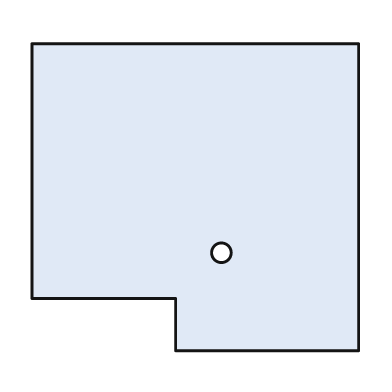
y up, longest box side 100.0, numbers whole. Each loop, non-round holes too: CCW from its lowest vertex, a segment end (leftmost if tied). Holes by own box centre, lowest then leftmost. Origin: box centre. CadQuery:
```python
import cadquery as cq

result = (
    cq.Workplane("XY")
    .moveTo(-6.0, -47.0)
    .lineTo(50.0, -47.0)
    .lineTo(50.0, 47.0)
    .lineTo(-50.0, 47.0)
    .lineTo(-50.0, -31.0)
    .lineTo(-6.0, -31.0)
    .close()
    .moveTo(8.0, -17.0)
    .circle(3.0)
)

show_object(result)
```